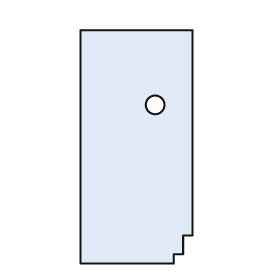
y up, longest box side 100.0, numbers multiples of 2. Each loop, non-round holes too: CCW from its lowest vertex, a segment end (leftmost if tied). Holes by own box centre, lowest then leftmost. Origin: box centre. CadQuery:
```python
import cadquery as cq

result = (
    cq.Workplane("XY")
    .moveTo(-24.0, -50.0)
    .lineTo(16.0, -50.0)
    .lineTo(16.0, -46.0)
    .lineTo(20.0, -46.0)
    .lineTo(20.0, -38.0)
    .lineTo(24.0, -38.0)
    .lineTo(24.0, 50.0)
    .lineTo(-24.0, 50.0)
    .close()
    .moveTo(8.0, 18.0)
    .circle(4.0)
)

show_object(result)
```